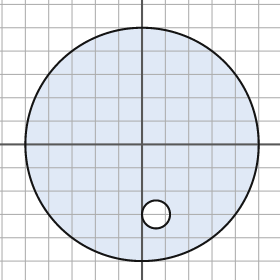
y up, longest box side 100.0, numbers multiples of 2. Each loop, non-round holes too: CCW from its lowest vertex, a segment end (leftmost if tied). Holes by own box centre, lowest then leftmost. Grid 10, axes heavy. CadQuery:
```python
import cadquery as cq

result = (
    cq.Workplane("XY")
    .moveTo(0.0, 0.0)
    .circle(50.0)
    .moveTo(6.0, -30.0)
    .circle(6.0)
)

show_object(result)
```